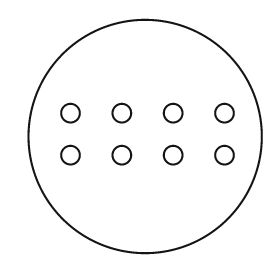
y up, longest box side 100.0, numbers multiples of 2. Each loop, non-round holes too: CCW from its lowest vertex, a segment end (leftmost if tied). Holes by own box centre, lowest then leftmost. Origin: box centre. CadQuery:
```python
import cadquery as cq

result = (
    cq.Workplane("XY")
    .moveTo(0.0, 0.0)
    .circle(50.0)
    .moveTo(-32.0, -8.0)
    .circle(4.0)
    .moveTo(-10.0, -8.0)
    .circle(4.0)
    .moveTo(12.0, -8.0)
    .circle(4.0)
    .moveTo(34.0, -8.0)
    .circle(4.0)
    .moveTo(-32.0, 10.0)
    .circle(4.0)
    .moveTo(-10.0, 10.0)
    .circle(4.0)
    .moveTo(12.0, 10.0)
    .circle(4.0)
    .moveTo(34.0, 10.0)
    .circle(4.0)
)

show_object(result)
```